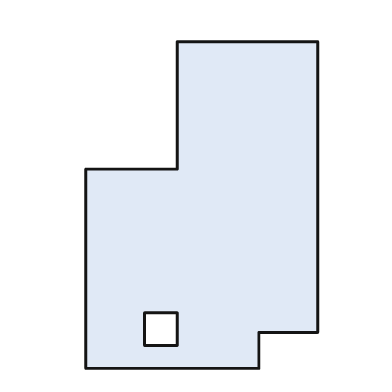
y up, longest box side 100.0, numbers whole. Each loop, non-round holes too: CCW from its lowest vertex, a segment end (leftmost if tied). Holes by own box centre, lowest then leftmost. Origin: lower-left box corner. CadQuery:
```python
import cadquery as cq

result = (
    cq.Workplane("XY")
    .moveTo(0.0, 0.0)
    .lineTo(53.0, 0.0)
    .lineTo(53.0, 11.0)
    .lineTo(71.0, 11.0)
    .lineTo(71.0, 100.0)
    .lineTo(28.0, 100.0)
    .lineTo(28.0, 61.0)
    .lineTo(0.0, 61.0)
    .close()
    .moveTo(18.0, 7.0)
    .lineTo(28.0, 7.0)
    .lineTo(28.0, 17.0)
    .lineTo(18.0, 17.0)
    .close()
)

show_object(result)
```